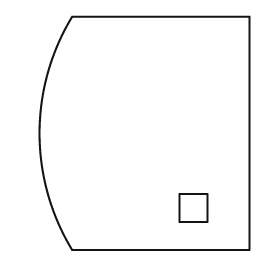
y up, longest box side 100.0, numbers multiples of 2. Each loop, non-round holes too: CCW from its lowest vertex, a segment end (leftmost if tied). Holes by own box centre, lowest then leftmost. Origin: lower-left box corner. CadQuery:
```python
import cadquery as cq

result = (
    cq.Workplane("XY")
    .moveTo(14.0, 0.0)
    .lineTo(90.0, 0.0)
    .lineTo(90.0, 100.0)
    .lineTo(14.0, 100.0)
    .threePointArc((0.0, 50.0), (14.0, 0.0))
    .close()
    .moveTo(60.0, 12.0)
    .lineTo(72.0, 12.0)
    .lineTo(72.0, 24.0)
    .lineTo(60.0, 24.0)
    .close()
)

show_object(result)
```